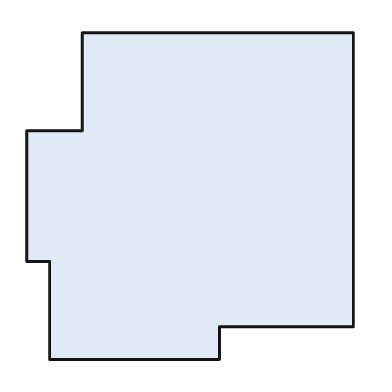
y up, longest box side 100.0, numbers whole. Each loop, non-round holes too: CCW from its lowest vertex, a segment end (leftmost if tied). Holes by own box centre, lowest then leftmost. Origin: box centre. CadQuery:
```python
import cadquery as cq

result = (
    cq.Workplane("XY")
    .moveTo(-43.0, -50.0)
    .lineTo(9.0, -50.0)
    .lineTo(9.0, -40.0)
    .lineTo(50.0, -40.0)
    .lineTo(50.0, 50.0)
    .lineTo(-33.0, 50.0)
    .lineTo(-33.0, 20.0)
    .lineTo(-50.0, 20.0)
    .lineTo(-50.0, -20.0)
    .lineTo(-43.0, -20.0)
    .close()
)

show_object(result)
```